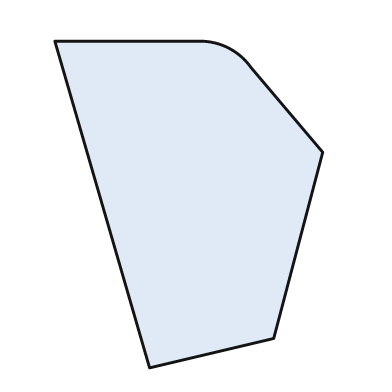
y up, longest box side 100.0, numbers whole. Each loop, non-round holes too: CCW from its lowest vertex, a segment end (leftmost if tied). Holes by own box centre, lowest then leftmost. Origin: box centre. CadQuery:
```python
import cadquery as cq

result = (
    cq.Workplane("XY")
    .moveTo(-12.0, -50.0)
    .lineTo(26.0, -41.0)
    .lineTo(41.0, 16.0)
    .lineTo(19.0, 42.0)
    .threePointArc((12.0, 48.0), (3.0, 50.0))
    .lineTo(-41.0, 50.0)
    .close()
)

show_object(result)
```